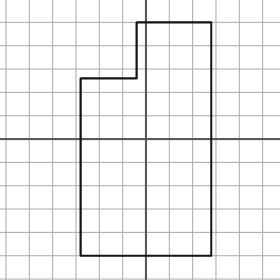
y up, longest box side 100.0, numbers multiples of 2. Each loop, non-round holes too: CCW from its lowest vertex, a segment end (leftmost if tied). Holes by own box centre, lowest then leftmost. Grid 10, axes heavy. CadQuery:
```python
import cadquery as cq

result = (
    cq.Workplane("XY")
    .moveTo(-28.0, -50.0)
    .lineTo(28.0, -50.0)
    .lineTo(28.0, 50.0)
    .lineTo(-4.0, 50.0)
    .lineTo(-4.0, 26.0)
    .lineTo(-28.0, 26.0)
    .close()
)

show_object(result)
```